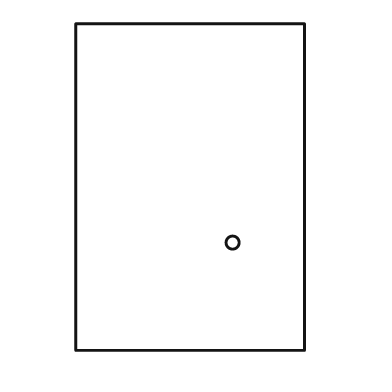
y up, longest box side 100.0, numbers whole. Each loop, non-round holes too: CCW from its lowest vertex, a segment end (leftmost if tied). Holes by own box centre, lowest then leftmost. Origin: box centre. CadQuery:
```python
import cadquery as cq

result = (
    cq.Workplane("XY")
    .moveTo(-35.0, -50.0)
    .lineTo(35.0, -50.0)
    .lineTo(35.0, 50.0)
    .lineTo(-35.0, 50.0)
    .close()
    .moveTo(13.0, -17.0)
    .circle(2.0)
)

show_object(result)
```